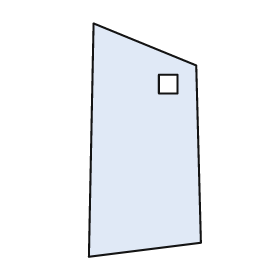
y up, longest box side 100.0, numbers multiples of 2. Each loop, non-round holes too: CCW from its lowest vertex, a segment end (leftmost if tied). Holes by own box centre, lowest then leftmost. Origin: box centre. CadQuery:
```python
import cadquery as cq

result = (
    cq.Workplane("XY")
    .moveTo(-24.0, -50.0)
    .lineTo(24.0, -44.0)
    .lineTo(22.0, 32.0)
    .lineTo(-22.0, 50.0)
    .close()
    .moveTo(6.0, 20.0)
    .lineTo(14.0, 20.0)
    .lineTo(14.0, 28.0)
    .lineTo(6.0, 28.0)
    .close()
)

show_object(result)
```